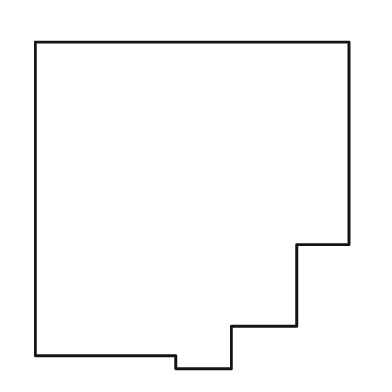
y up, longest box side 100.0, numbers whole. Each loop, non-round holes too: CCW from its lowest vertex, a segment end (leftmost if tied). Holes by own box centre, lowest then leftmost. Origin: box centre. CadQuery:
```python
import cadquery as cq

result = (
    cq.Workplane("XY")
    .moveTo(-5.0, -50.0)
    .lineTo(12.0, -50.0)
    .lineTo(12.0, -37.0)
    .lineTo(32.0, -37.0)
    .lineTo(32.0, -12.0)
    .lineTo(48.0, -12.0)
    .lineTo(48.0, 50.0)
    .lineTo(-48.0, 50.0)
    .lineTo(-48.0, -46.0)
    .lineTo(-5.0, -46.0)
    .close()
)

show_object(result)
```